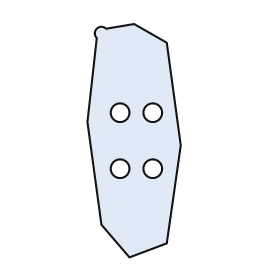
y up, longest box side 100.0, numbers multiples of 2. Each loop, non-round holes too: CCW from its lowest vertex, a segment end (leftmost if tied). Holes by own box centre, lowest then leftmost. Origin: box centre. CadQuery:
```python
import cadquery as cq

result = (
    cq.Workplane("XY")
    .moveTo(-2.0, -50.0)
    .lineTo(14.0, -44.0)
    .lineTo(20.0, -2.0)
    .lineTo(14.0, 42.0)
    .lineTo(0.0, 50.0)
    .lineTo(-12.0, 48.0)
    .threePointArc((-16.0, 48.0), (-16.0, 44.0))
    .lineTo(-20.0, 8.0)
    .lineTo(-14.0, -36.0)
    .close()
    .moveTo(-6.0, -12.0)
    .circle(4.0)
    .moveTo(8.0, -12.0)
    .circle(4.0)
    .moveTo(-6.0, 12.0)
    .circle(4.0)
    .moveTo(8.0, 12.0)
    .circle(4.0)
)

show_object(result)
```